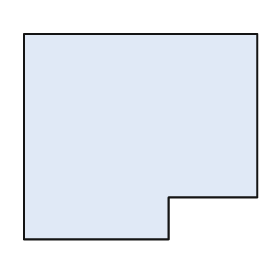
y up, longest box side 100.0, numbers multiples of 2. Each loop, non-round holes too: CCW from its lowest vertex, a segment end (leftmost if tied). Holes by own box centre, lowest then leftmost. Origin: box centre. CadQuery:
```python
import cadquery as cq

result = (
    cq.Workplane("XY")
    .moveTo(-50.0, -44.0)
    .lineTo(12.0, -44.0)
    .lineTo(12.0, -26.0)
    .lineTo(50.0, -26.0)
    .lineTo(50.0, 44.0)
    .lineTo(-50.0, 44.0)
    .close()
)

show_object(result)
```